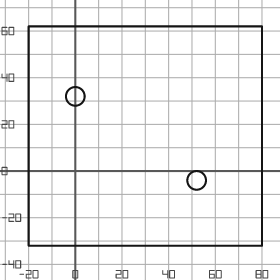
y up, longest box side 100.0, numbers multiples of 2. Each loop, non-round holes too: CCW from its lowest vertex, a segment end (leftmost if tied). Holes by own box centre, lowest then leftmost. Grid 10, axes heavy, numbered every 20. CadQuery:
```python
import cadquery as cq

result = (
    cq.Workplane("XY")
    .moveTo(-20.0, -32.0)
    .lineTo(80.0, -32.0)
    .lineTo(80.0, 62.0)
    .lineTo(-20.0, 62.0)
    .close()
    .moveTo(52.0, -4.0)
    .circle(4.0)
    .moveTo(0.0, 32.0)
    .circle(4.0)
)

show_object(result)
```